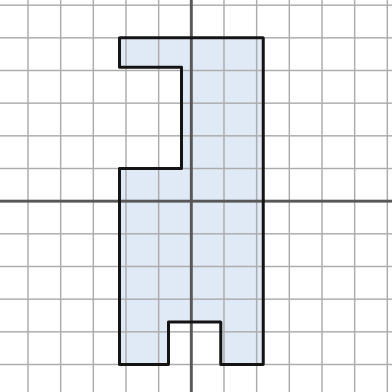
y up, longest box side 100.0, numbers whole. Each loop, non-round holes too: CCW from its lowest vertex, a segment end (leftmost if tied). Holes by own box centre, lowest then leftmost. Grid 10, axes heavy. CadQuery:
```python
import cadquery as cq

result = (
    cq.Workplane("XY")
    .moveTo(-22.0, -50.0)
    .lineTo(-7.0, -50.0)
    .lineTo(-7.0, -37.0)
    .lineTo(9.0, -37.0)
    .lineTo(9.0, -50.0)
    .lineTo(22.0, -50.0)
    .lineTo(22.0, 50.0)
    .lineTo(-22.0, 50.0)
    .lineTo(-22.0, 41.0)
    .lineTo(-3.0, 41.0)
    .lineTo(-3.0, 10.0)
    .lineTo(-22.0, 10.0)
    .close()
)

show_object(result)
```